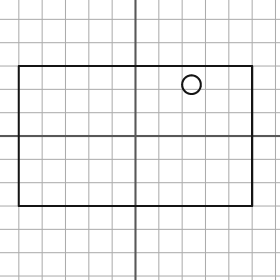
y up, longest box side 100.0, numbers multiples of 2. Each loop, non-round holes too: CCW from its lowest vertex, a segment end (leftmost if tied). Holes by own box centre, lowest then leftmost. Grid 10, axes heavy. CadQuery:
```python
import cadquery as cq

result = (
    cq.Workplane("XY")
    .moveTo(-50.0, -30.0)
    .lineTo(50.0, -30.0)
    .lineTo(50.0, 30.0)
    .lineTo(-50.0, 30.0)
    .close()
    .moveTo(24.0, 22.0)
    .circle(4.0)
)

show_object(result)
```